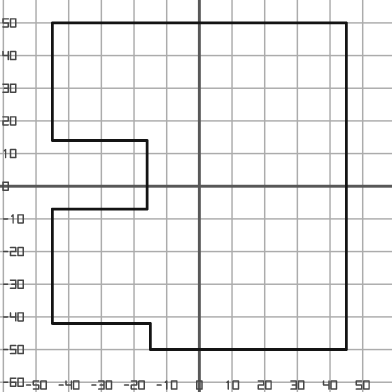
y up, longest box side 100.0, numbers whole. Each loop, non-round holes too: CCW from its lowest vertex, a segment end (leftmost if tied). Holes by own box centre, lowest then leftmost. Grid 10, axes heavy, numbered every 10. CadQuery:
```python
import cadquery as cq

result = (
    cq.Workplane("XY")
    .moveTo(-15.0, -50.0)
    .lineTo(45.0, -50.0)
    .lineTo(45.0, 50.0)
    .lineTo(-45.0, 50.0)
    .lineTo(-45.0, 14.0)
    .lineTo(-16.0, 14.0)
    .lineTo(-16.0, -7.0)
    .lineTo(-45.0, -7.0)
    .lineTo(-45.0, -42.0)
    .lineTo(-15.0, -42.0)
    .close()
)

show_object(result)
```